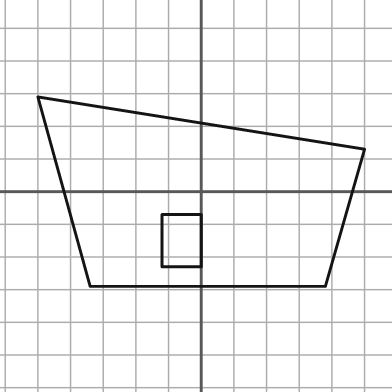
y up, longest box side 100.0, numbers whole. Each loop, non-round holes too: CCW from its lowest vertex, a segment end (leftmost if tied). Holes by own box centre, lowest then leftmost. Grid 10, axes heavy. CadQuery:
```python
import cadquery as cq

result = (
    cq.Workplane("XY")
    .moveTo(-34.0, -29.0)
    .lineTo(38.0, -29.0)
    .lineTo(50.0, 13.0)
    .lineTo(-50.0, 29.0)
    .close()
    .moveTo(-12.0, -23.0)
    .lineTo(0.0, -23.0)
    .lineTo(0.0, -7.0)
    .lineTo(-12.0, -7.0)
    .close()
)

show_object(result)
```